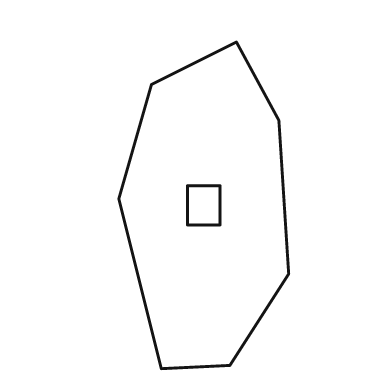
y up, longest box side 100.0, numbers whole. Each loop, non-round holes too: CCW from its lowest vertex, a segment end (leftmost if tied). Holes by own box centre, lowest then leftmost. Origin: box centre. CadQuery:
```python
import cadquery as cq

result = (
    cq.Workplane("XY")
    .moveTo(-13.0, -50.0)
    .lineTo(8.0, -49.0)
    .lineTo(26.0, -21.0)
    .lineTo(23.0, 26.0)
    .lineTo(10.0, 50.0)
    .lineTo(-16.0, 37.0)
    .lineTo(-26.0, 2.0)
    .close()
    .moveTo(-5.0, -6.0)
    .lineTo(5.0, -6.0)
    .lineTo(5.0, 6.0)
    .lineTo(-5.0, 6.0)
    .close()
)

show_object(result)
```